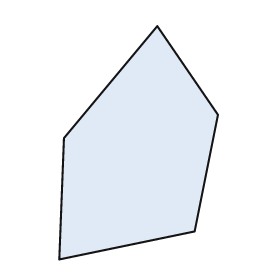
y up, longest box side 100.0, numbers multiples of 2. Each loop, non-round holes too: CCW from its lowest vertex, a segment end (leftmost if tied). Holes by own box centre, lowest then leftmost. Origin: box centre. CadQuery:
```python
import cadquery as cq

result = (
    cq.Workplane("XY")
    .moveTo(-34.0, -50.0)
    .lineTo(24.0, -38.0)
    .lineTo(34.0, 12.0)
    .lineTo(8.0, 50.0)
    .lineTo(-32.0, 2.0)
    .close()
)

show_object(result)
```